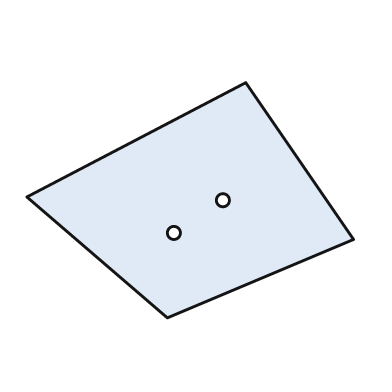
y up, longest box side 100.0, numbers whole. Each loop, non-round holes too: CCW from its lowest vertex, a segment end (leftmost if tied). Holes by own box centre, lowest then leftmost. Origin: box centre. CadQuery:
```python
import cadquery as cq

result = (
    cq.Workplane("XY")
    .moveTo(-7.0, -36.0)
    .lineTo(50.0, -12.0)
    .lineTo(17.0, 36.0)
    .lineTo(-50.0, 1.0)
    .close()
    .moveTo(-5.0, -10.0)
    .circle(2.0)
    .moveTo(10.0, 0.0)
    .circle(2.0)
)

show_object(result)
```